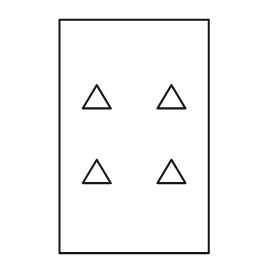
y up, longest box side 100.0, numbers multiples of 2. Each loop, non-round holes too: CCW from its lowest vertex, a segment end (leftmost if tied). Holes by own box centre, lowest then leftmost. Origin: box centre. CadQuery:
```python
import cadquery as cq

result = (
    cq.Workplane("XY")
    .moveTo(-32.0, -50.0)
    .lineTo(32.0, -50.0)
    .lineTo(32.0, 50.0)
    .lineTo(-32.0, 50.0)
    .close()
    .moveTo(-22.0, -20.0)
    .lineTo(-10.0, -20.0)
    .lineTo(-16.0, -10.0)
    .close()
    .moveTo(10.0, -20.0)
    .lineTo(22.0, -20.0)
    .lineTo(16.0, -10.0)
    .close()
    .moveTo(-22.0, 12.0)
    .lineTo(-10.0, 12.0)
    .lineTo(-16.0, 22.0)
    .close()
    .moveTo(10.0, 12.0)
    .lineTo(22.0, 12.0)
    .lineTo(16.0, 22.0)
    .close()
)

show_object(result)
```